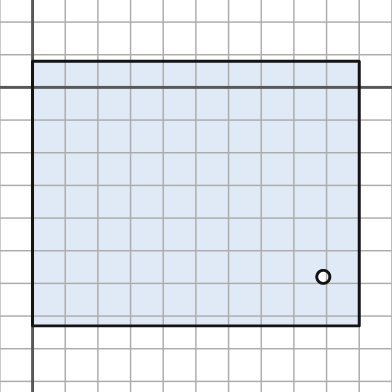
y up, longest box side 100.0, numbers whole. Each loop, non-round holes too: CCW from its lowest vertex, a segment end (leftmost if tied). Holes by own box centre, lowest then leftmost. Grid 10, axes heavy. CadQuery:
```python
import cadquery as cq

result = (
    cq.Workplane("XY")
    .moveTo(0.0, -73.0)
    .lineTo(100.0, -73.0)
    .lineTo(100.0, 8.0)
    .lineTo(0.0, 8.0)
    .close()
    .moveTo(89.0, -58.0)
    .circle(2.0)
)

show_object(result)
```